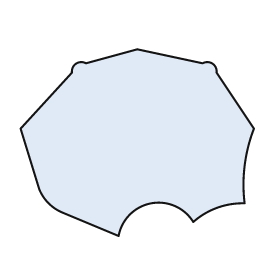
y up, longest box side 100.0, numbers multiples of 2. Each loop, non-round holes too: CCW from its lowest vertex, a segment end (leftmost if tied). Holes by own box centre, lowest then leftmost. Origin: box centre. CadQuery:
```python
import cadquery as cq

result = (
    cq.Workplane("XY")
    .moveTo(-8.0, -40.0)
    .threePointArc((6.0, -26.0), (24.0, -34.0))
    .threePointArc((34.0, -28.0), (46.0, -26.0))
    .threePointArc((46.0, -10.0), (50.0, 6.0))
    .lineTo(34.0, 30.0)
    .threePointArc((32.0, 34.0), (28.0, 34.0))
    .lineTo(0.0, 40.0)
    .lineTo(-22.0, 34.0)
    .threePointArc((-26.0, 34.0), (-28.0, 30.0))
    .lineTo(-50.0, 6.0)
    .lineTo(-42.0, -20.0)
    .threePointArc((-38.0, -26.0), (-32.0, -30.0))
    .close()
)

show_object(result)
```